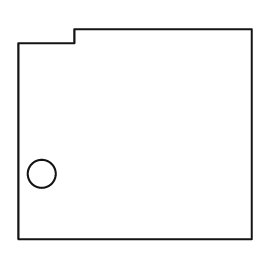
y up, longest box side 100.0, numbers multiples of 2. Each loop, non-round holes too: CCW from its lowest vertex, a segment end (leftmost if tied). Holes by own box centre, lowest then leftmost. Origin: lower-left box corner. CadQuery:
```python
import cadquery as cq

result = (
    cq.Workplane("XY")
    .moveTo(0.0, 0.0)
    .lineTo(100.0, 0.0)
    .lineTo(100.0, 90.0)
    .lineTo(24.0, 90.0)
    .lineTo(24.0, 84.0)
    .lineTo(0.0, 84.0)
    .close()
    .moveTo(10.0, 28.0)
    .circle(6.0)
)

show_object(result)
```